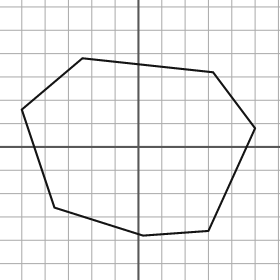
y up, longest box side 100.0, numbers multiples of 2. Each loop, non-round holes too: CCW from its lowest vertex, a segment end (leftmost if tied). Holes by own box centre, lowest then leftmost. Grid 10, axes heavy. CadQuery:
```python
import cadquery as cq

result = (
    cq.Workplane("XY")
    .moveTo(2.0, -38.0)
    .lineTo(30.0, -36.0)
    .lineTo(50.0, 8.0)
    .lineTo(32.0, 32.0)
    .lineTo(-24.0, 38.0)
    .lineTo(-50.0, 16.0)
    .lineTo(-36.0, -26.0)
    .close()
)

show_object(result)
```